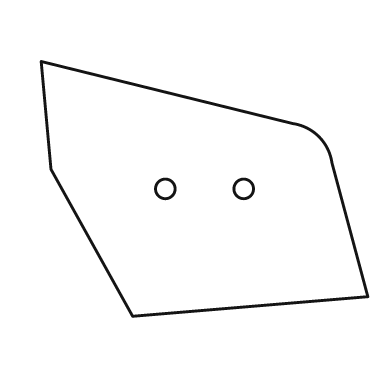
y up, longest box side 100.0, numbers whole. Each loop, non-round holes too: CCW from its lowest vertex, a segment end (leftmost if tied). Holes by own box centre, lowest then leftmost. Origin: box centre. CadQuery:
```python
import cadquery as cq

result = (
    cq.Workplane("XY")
    .moveTo(-22.0, -39.0)
    .lineTo(50.0, -33.0)
    .lineTo(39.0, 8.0)
    .threePointArc((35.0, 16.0), (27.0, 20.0))
    .lineTo(-50.0, 39.0)
    .lineTo(-47.0, 6.0)
    .close()
    .moveTo(-12.0, 0.0)
    .circle(3.0)
    .moveTo(12.0, 0.0)
    .circle(3.0)
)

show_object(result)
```